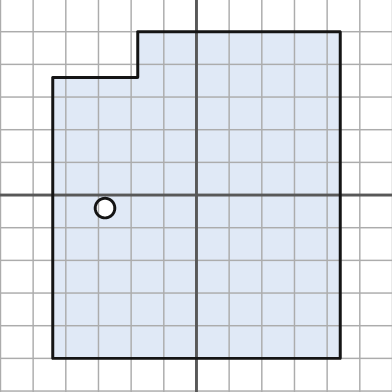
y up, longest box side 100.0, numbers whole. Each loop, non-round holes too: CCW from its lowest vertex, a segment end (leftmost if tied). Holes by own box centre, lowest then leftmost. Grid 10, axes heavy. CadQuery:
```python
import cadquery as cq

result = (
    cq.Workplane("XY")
    .moveTo(-44.0, -50.0)
    .lineTo(44.0, -50.0)
    .lineTo(44.0, 50.0)
    .lineTo(-18.0, 50.0)
    .lineTo(-18.0, 36.0)
    .lineTo(-44.0, 36.0)
    .close()
    .moveTo(-28.0, -4.0)
    .circle(3.0)
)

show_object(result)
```